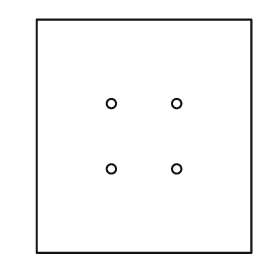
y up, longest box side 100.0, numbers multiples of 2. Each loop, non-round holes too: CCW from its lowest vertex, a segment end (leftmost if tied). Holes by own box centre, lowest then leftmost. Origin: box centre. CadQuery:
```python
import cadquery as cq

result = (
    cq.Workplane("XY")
    .moveTo(-46.0, -50.0)
    .lineTo(46.0, -50.0)
    .lineTo(46.0, 50.0)
    .lineTo(-46.0, 50.0)
    .close()
    .moveTo(-14.0, -14.0)
    .circle(2.0)
    .moveTo(14.0, -14.0)
    .circle(2.0)
    .moveTo(-14.0, 14.0)
    .circle(2.0)
    .moveTo(14.0, 14.0)
    .circle(2.0)
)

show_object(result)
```